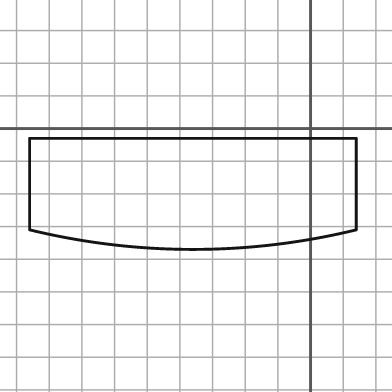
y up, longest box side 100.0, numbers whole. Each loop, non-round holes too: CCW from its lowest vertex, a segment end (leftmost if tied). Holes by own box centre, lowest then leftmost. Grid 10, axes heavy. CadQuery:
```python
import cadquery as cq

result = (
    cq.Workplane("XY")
    .moveTo(-86.0, -31.0)
    .threePointArc((-36.0, -37.0), (14.0, -31.0))
    .lineTo(14.0, -3.0)
    .lineTo(-86.0, -3.0)
    .close()
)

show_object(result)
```